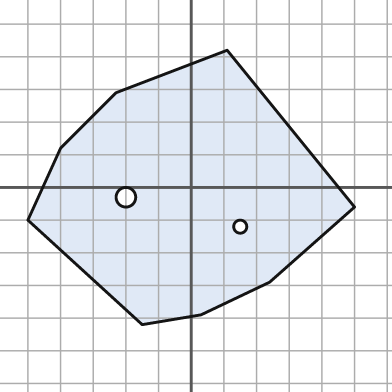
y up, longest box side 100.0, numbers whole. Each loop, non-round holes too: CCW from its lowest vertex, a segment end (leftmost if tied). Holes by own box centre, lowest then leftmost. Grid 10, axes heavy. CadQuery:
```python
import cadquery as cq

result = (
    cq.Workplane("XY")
    .moveTo(-15.0, -42.0)
    .lineTo(3.0, -39.0)
    .lineTo(24.0, -29.0)
    .lineTo(50.0, -6.0)
    .lineTo(11.0, 42.0)
    .lineTo(-23.0, 29.0)
    .lineTo(-40.0, 12.0)
    .lineTo(-50.0, -10.0)
    .close()
    .moveTo(15.0, -12.0)
    .circle(2.0)
    .moveTo(-20.0, -3.0)
    .circle(3.0)
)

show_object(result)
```